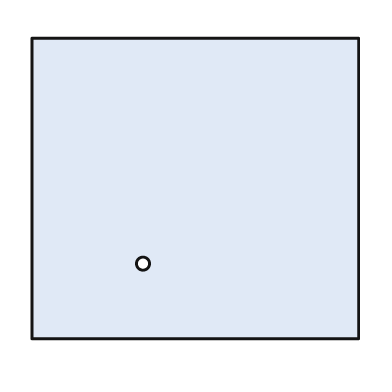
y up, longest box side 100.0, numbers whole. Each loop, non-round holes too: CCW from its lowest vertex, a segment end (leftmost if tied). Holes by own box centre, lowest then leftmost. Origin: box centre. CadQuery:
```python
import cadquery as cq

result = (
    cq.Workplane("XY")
    .moveTo(-50.0, -46.0)
    .lineTo(50.0, -46.0)
    .lineTo(50.0, 46.0)
    .lineTo(-50.0, 46.0)
    .close()
    .moveTo(-16.0, -23.0)
    .circle(2.0)
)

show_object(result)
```